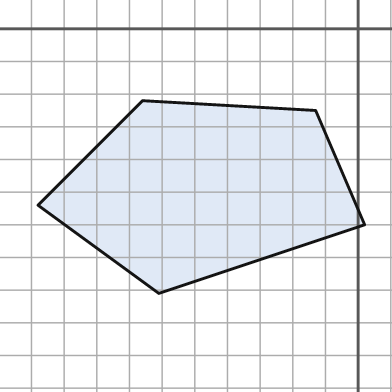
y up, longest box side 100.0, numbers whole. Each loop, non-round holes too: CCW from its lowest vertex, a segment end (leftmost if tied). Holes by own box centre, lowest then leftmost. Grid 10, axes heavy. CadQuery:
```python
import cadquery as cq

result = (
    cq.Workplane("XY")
    .moveTo(-61.0, -81.0)
    .lineTo(2.0, -60.0)
    .lineTo(-13.0, -25.0)
    .lineTo(-66.0, -22.0)
    .lineTo(-98.0, -54.0)
    .close()
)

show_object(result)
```